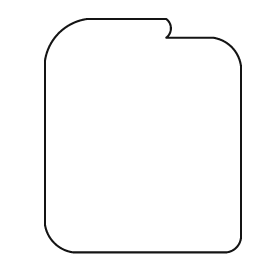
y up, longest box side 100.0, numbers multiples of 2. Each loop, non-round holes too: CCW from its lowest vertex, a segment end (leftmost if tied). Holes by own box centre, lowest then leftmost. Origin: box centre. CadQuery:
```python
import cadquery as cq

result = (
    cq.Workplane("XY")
    .moveTo(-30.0, -50.0)
    .lineTo(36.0, -50.0)
    .threePointArc((40.0, -48.0), (42.0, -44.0))
    .lineTo(42.0, 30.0)
    .threePointArc((38.0, 38.0), (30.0, 42.0))
    .lineTo(10.0, 42.0)
    .threePointArc((12.0, 46.0), (10.0, 50.0))
    .lineTo(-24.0, 50.0)
    .threePointArc((-36.0, 44.0), (-42.0, 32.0))
    .lineTo(-42.0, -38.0)
    .threePointArc((-38.0, -46.0), (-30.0, -50.0))
    .close()
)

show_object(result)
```